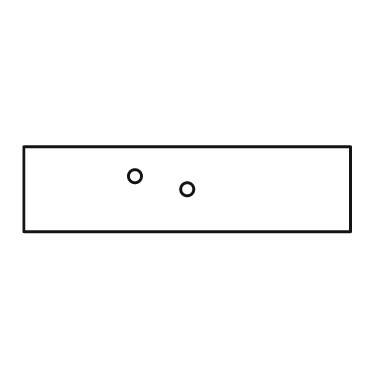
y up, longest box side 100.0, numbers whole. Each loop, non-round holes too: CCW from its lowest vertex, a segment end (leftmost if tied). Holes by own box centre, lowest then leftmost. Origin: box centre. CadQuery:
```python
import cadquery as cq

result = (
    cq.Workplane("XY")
    .moveTo(-50.0, -13.0)
    .lineTo(50.0, -13.0)
    .lineTo(50.0, 13.0)
    .lineTo(-50.0, 13.0)
    .close()
    .moveTo(0.0, 0.0)
    .circle(2.0)
    .moveTo(-16.0, 4.0)
    .circle(2.0)
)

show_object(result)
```